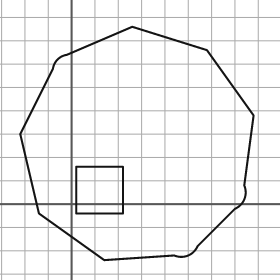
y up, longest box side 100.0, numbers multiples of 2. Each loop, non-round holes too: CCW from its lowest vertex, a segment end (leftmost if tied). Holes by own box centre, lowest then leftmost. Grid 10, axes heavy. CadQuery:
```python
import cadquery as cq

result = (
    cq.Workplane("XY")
    .moveTo(14.0, -24.0)
    .lineTo(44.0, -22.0)
    .threePointArc((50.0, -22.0), (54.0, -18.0))
    .lineTo(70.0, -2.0)
    .threePointArc((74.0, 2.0), (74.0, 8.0))
    .lineTo(78.0, 38.0)
    .lineTo(58.0, 66.0)
    .lineTo(26.0, 76.0)
    .lineTo(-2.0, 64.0)
    .threePointArc((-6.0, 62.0), (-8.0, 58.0))
    .lineTo(-22.0, 30.0)
    .lineTo(-14.0, -4.0)
    .close()
    .moveTo(2.0, -4.0)
    .lineTo(22.0, -4.0)
    .lineTo(22.0, 16.0)
    .lineTo(2.0, 16.0)
    .close()
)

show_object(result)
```